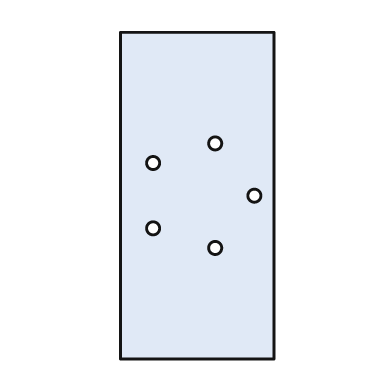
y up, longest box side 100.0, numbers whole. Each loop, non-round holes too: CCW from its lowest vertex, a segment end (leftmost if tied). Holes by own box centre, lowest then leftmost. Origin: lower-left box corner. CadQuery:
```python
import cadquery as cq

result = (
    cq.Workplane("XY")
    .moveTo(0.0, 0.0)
    .lineTo(47.0, 0.0)
    .lineTo(47.0, 100.0)
    .lineTo(0.0, 100.0)
    .close()
    .moveTo(29.0, 34.0)
    .circle(2.0)
    .moveTo(10.0, 40.0)
    .circle(2.0)
    .moveTo(41.0, 50.0)
    .circle(2.0)
    .moveTo(10.0, 60.0)
    .circle(2.0)
    .moveTo(29.0, 66.0)
    .circle(2.0)
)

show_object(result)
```